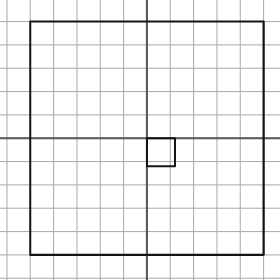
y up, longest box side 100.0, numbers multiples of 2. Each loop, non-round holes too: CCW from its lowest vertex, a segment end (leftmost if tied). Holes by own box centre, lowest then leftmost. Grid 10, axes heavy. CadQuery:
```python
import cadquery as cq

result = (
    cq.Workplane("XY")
    .moveTo(-50.0, -50.0)
    .lineTo(50.0, -50.0)
    .lineTo(50.0, 50.0)
    .lineTo(-50.0, 50.0)
    .close()
    .moveTo(0.0, -12.0)
    .lineTo(12.0, -12.0)
    .lineTo(12.0, 0.0)
    .lineTo(0.0, 0.0)
    .close()
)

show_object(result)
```